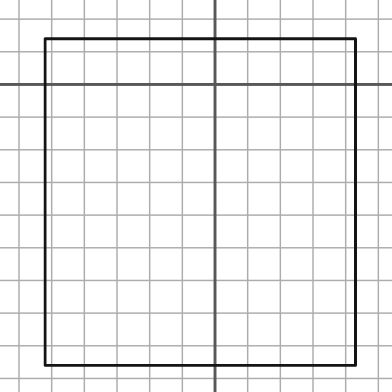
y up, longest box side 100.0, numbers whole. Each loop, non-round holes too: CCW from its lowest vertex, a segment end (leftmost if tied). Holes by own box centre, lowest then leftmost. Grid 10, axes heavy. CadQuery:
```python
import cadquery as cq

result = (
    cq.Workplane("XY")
    .moveTo(-52.0, -86.0)
    .lineTo(43.0, -86.0)
    .lineTo(43.0, 14.0)
    .lineTo(-52.0, 14.0)
    .close()
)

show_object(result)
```